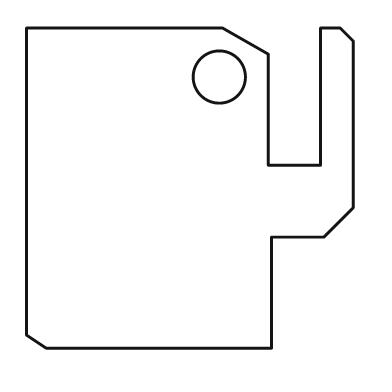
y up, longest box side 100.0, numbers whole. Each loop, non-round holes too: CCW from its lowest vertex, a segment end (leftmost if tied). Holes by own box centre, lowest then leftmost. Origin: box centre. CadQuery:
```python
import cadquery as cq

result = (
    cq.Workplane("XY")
    .moveTo(-44.0, -49.0)
    .lineTo(25.0, -49.0)
    .lineTo(25.0, -15.0)
    .lineTo(41.0, -15.0)
    .lineTo(50.0, -6.0)
    .lineTo(50.0, 45.0)
    .lineTo(46.0, 49.0)
    .lineTo(40.0, 49.0)
    .lineTo(40.0, 7.0)
    .lineTo(24.0, 7.0)
    .lineTo(24.0, 41.0)
    .lineTo(10.0, 49.0)
    .lineTo(-50.0, 49.0)
    .lineTo(-50.0, -45.0)
    .close()
    .moveTo(9.0, 34.0)
    .circle(8.0)
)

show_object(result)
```